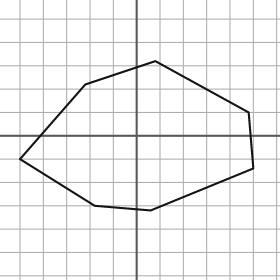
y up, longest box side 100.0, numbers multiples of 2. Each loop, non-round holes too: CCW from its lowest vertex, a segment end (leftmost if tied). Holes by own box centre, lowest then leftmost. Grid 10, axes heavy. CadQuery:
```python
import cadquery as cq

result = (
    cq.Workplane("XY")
    .moveTo(6.0, -32.0)
    .lineTo(50.0, -14.0)
    .lineTo(48.0, 10.0)
    .lineTo(8.0, 32.0)
    .lineTo(-22.0, 22.0)
    .lineTo(-50.0, -10.0)
    .lineTo(-18.0, -30.0)
    .close()
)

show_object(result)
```